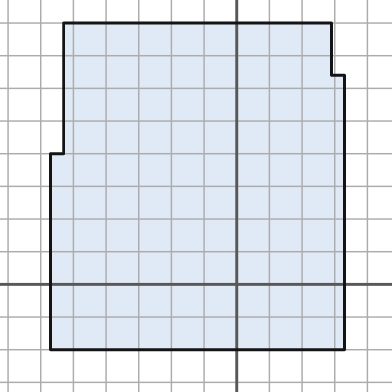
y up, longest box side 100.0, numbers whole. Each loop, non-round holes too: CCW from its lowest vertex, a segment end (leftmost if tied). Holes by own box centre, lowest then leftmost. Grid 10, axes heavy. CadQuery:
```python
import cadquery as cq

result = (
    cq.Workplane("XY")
    .moveTo(-57.0, -20.0)
    .lineTo(33.0, -20.0)
    .lineTo(33.0, 64.0)
    .lineTo(29.0, 64.0)
    .lineTo(29.0, 80.0)
    .lineTo(-53.0, 80.0)
    .lineTo(-53.0, 40.0)
    .lineTo(-57.0, 40.0)
    .close()
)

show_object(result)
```